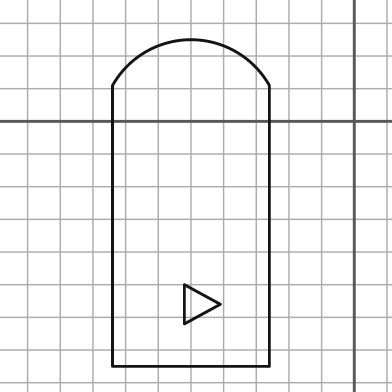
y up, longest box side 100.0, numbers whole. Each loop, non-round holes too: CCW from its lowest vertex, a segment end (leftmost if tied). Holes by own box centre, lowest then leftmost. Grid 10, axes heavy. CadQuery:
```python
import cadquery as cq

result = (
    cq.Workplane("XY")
    .moveTo(-74.0, -75.0)
    .lineTo(-26.0, -75.0)
    .lineTo(-26.0, 11.0)
    .threePointArc((-50.0, 25.0), (-74.0, 11.0))
    .close()
    .moveTo(-52.0, -62.0)
    .lineTo(-41.0, -56.0)
    .lineTo(-52.0, -50.0)
    .close()
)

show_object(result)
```